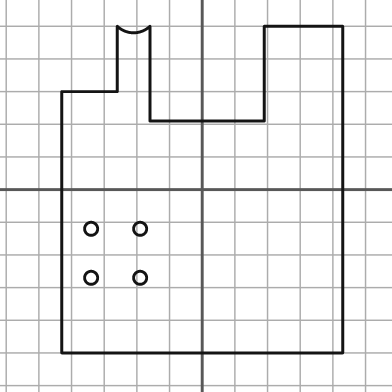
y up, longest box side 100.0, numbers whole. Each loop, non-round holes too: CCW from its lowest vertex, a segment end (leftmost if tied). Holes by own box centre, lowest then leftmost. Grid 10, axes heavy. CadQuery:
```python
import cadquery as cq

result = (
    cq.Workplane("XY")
    .moveTo(-43.0, -50.0)
    .lineTo(43.0, -50.0)
    .lineTo(43.0, 50.0)
    .lineTo(19.0, 50.0)
    .lineTo(19.0, 21.0)
    .lineTo(-16.0, 21.0)
    .lineTo(-16.0, 50.0)
    .threePointArc((-21.0, 48.0), (-26.0, 50.0))
    .lineTo(-26.0, 30.0)
    .lineTo(-43.0, 30.0)
    .close()
    .moveTo(-34.0, -27.0)
    .circle(2.0)
    .moveTo(-19.0, -27.0)
    .circle(2.0)
    .moveTo(-34.0, -12.0)
    .circle(2.0)
    .moveTo(-19.0, -12.0)
    .circle(2.0)
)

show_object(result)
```